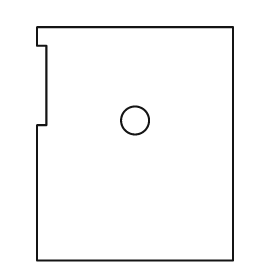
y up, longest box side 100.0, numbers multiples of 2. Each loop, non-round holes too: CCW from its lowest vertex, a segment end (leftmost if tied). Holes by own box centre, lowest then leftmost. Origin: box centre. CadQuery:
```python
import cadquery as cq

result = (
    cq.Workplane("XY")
    .moveTo(-42.0, -50.0)
    .lineTo(42.0, -50.0)
    .lineTo(42.0, 50.0)
    .lineTo(-42.0, 50.0)
    .lineTo(-42.0, 42.0)
    .lineTo(-38.0, 42.0)
    .lineTo(-38.0, 8.0)
    .lineTo(-42.0, 8.0)
    .close()
    .moveTo(0.0, 10.0)
    .circle(6.0)
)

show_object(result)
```